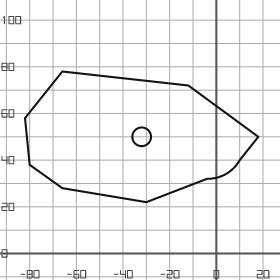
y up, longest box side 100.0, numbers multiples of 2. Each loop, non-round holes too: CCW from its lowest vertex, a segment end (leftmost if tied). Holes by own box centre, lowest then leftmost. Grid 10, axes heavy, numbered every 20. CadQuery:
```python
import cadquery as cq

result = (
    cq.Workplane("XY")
    .moveTo(-30.0, 22.0)
    .lineTo(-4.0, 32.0)
    .threePointArc((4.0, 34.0), (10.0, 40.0))
    .lineTo(18.0, 50.0)
    .lineTo(-12.0, 72.0)
    .lineTo(-66.0, 78.0)
    .lineTo(-82.0, 58.0)
    .lineTo(-80.0, 38.0)
    .lineTo(-66.0, 28.0)
    .close()
    .moveTo(-32.0, 50.0)
    .circle(4.0)
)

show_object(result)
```